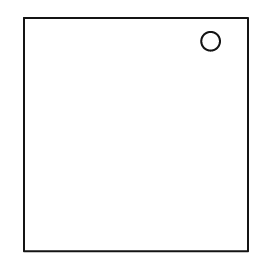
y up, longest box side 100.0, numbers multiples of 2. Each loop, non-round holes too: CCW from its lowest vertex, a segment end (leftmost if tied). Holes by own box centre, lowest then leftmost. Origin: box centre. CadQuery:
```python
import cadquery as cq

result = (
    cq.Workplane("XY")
    .moveTo(-48.0, -50.0)
    .lineTo(48.0, -50.0)
    .lineTo(48.0, 50.0)
    .lineTo(-48.0, 50.0)
    .close()
    .moveTo(32.0, 40.0)
    .circle(4.0)
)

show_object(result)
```